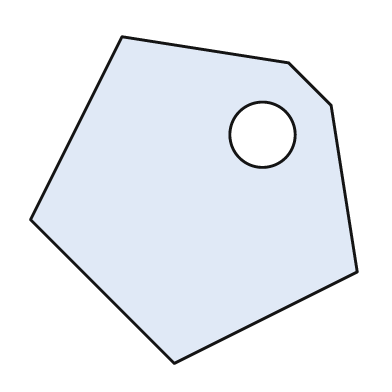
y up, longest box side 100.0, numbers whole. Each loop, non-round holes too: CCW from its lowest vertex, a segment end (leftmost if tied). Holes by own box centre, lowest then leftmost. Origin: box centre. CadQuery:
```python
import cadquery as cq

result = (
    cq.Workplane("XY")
    .moveTo(-6.0, -50.0)
    .lineTo(50.0, -22.0)
    .lineTo(42.0, 29.0)
    .lineTo(29.0, 42.0)
    .lineTo(-22.0, 50.0)
    .lineTo(-50.0, -6.0)
    .close()
    .moveTo(21.0, 20.0)
    .circle(10.0)
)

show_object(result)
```